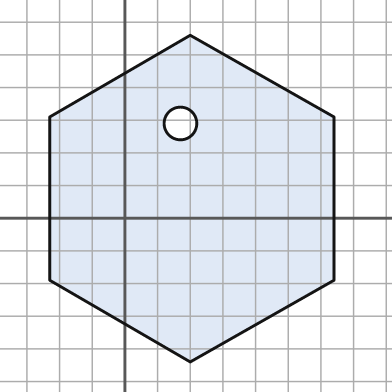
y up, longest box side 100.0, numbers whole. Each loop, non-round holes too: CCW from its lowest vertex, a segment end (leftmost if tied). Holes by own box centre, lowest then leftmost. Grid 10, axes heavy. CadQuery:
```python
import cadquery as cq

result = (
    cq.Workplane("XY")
    .moveTo(20.0, -44.0)
    .lineTo(64.0, -19.0)
    .lineTo(64.0, 31.0)
    .lineTo(20.0, 56.0)
    .lineTo(-23.0, 31.0)
    .lineTo(-23.0, -19.0)
    .close()
    .moveTo(17.0, 29.0)
    .circle(5.0)
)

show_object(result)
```